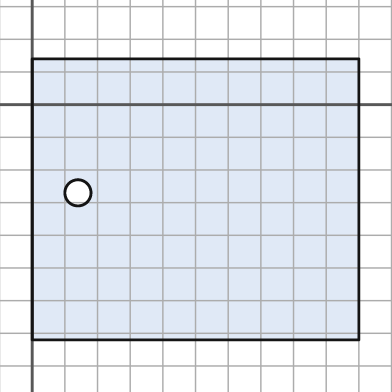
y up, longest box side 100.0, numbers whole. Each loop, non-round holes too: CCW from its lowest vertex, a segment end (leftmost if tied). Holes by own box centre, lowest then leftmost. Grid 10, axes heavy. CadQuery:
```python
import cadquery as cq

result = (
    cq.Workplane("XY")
    .moveTo(0.0, -72.0)
    .lineTo(100.0, -72.0)
    .lineTo(100.0, 14.0)
    .lineTo(0.0, 14.0)
    .close()
    .moveTo(14.0, -27.0)
    .circle(4.0)
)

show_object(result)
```